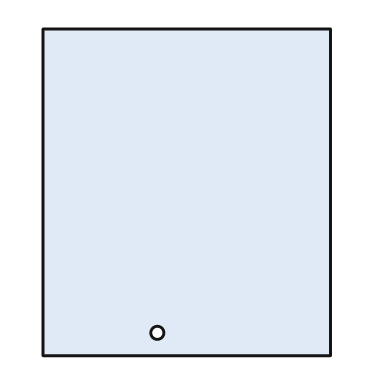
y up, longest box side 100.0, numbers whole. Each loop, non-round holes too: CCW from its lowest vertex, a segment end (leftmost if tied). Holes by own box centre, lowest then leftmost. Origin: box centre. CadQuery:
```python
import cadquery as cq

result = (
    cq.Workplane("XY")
    .moveTo(-44.0, -50.0)
    .lineTo(44.0, -50.0)
    .lineTo(44.0, 50.0)
    .lineTo(-44.0, 50.0)
    .close()
    .moveTo(-9.0, -43.0)
    .circle(2.0)
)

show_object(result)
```